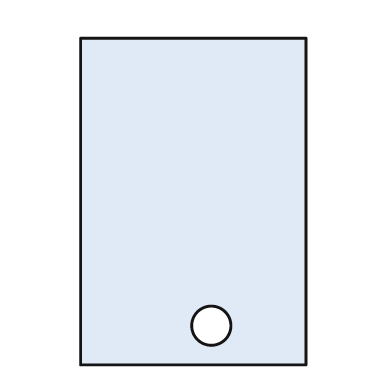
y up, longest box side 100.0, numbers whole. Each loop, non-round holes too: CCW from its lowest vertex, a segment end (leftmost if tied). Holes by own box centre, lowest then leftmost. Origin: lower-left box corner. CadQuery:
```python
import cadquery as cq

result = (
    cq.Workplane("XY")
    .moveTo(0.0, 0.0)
    .lineTo(69.0, 0.0)
    .lineTo(69.0, 100.0)
    .lineTo(0.0, 100.0)
    .close()
    .moveTo(40.0, 12.0)
    .circle(6.0)
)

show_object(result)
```